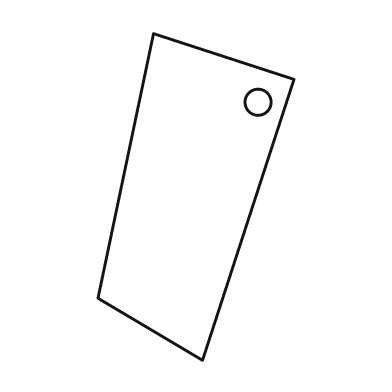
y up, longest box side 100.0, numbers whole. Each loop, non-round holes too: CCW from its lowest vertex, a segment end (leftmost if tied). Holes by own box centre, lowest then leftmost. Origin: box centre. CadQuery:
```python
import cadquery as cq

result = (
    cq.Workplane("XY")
    .moveTo(2.0, -50.0)
    .lineTo(30.0, 36.0)
    .lineTo(-13.0, 50.0)
    .lineTo(-30.0, -31.0)
    .close()
    .moveTo(19.0, 29.0)
    .circle(4.0)
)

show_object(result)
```